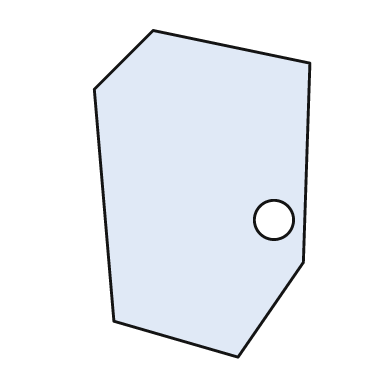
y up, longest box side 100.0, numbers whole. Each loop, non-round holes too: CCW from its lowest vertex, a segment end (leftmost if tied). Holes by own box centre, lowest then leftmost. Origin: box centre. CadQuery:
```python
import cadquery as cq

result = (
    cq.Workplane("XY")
    .moveTo(11.0, -50.0)
    .lineTo(31.0, -21.0)
    .lineTo(33.0, 40.0)
    .lineTo(-15.0, 50.0)
    .lineTo(-33.0, 32.0)
    .lineTo(-27.0, -39.0)
    .close()
    .moveTo(22.0, -8.0)
    .circle(6.0)
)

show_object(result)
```